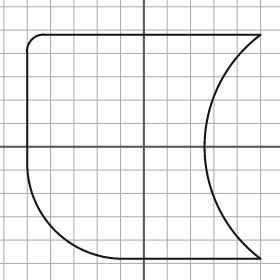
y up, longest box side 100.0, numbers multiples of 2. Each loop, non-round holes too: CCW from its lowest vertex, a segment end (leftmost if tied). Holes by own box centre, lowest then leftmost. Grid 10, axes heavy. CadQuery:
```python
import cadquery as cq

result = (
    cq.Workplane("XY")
    .moveTo(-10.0, -48.0)
    .lineTo(50.0, -48.0)
    .threePointArc((26.0, 0.0), (50.0, 48.0))
    .lineTo(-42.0, 48.0)
    .threePointArc((-48.0, 46.0), (-50.0, 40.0))
    .lineTo(-50.0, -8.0)
    .threePointArc((-38.0, -36.0), (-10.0, -48.0))
    .close()
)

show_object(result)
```